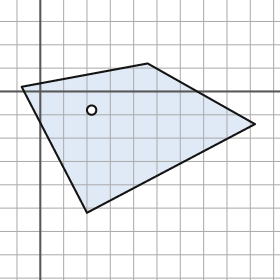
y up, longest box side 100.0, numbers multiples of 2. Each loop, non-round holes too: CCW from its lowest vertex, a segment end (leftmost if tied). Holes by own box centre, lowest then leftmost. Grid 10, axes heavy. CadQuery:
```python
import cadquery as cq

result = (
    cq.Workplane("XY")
    .moveTo(20.0, -52.0)
    .lineTo(92.0, -14.0)
    .lineTo(46.0, 12.0)
    .lineTo(-8.0, 2.0)
    .close()
    .moveTo(22.0, -8.0)
    .circle(2.0)
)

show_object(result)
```